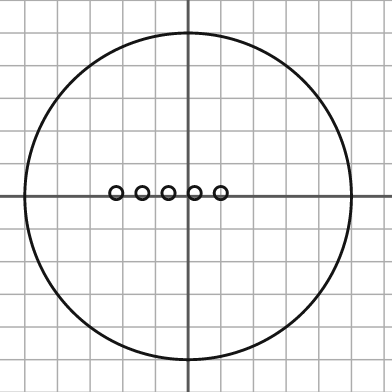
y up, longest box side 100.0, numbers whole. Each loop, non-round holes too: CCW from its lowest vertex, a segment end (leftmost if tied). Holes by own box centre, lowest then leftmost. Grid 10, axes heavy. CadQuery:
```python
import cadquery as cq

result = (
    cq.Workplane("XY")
    .moveTo(0.0, 0.0)
    .circle(50.0)
    .moveTo(-22.0, 1.0)
    .circle(2.0)
    .moveTo(-14.0, 1.0)
    .circle(2.0)
    .moveTo(-6.0, 1.0)
    .circle(2.0)
    .moveTo(2.0, 1.0)
    .circle(2.0)
    .moveTo(10.0, 1.0)
    .circle(2.0)
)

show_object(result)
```